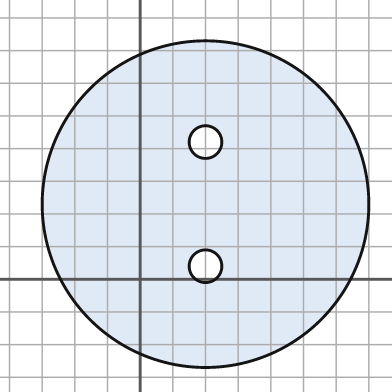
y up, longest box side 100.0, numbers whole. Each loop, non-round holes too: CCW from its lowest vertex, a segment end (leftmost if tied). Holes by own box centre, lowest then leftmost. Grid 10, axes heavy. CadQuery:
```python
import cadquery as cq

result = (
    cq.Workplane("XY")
    .moveTo(20.0, 23.0)
    .circle(50.0)
    .moveTo(20.0, 4.0)
    .circle(5.0)
    .moveTo(20.0, 42.0)
    .circle(5.0)
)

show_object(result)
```